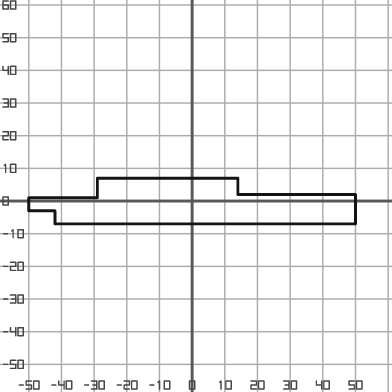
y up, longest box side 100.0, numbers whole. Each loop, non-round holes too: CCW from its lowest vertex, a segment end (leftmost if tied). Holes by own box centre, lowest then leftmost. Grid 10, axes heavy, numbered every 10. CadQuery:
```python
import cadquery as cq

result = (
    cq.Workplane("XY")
    .moveTo(-42.0, -7.0)
    .lineTo(50.0, -7.0)
    .lineTo(50.0, 2.0)
    .lineTo(14.0, 2.0)
    .lineTo(14.0, 7.0)
    .lineTo(-29.0, 7.0)
    .lineTo(-29.0, 1.0)
    .lineTo(-50.0, 1.0)
    .lineTo(-50.0, -3.0)
    .lineTo(-42.0, -3.0)
    .close()
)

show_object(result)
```